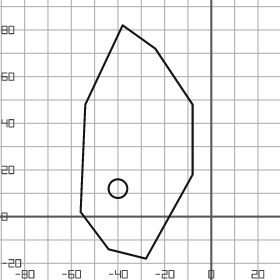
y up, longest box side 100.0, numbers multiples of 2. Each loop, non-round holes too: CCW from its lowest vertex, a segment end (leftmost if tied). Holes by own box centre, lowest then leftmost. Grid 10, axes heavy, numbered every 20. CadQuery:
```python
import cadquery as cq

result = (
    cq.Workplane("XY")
    .moveTo(-28.0, -18.0)
    .lineTo(-8.0, 18.0)
    .lineTo(-8.0, 48.0)
    .lineTo(-24.0, 72.0)
    .lineTo(-38.0, 82.0)
    .lineTo(-54.0, 48.0)
    .lineTo(-56.0, 2.0)
    .lineTo(-44.0, -14.0)
    .close()
    .moveTo(-40.0, 12.0)
    .circle(4.0)
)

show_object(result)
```